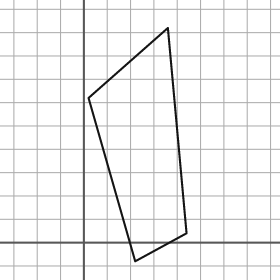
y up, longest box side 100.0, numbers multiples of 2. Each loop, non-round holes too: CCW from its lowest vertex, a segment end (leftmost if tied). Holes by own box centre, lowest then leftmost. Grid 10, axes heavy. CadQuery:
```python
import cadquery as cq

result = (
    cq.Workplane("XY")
    .moveTo(22.0, -8.0)
    .lineTo(44.0, 4.0)
    .lineTo(36.0, 92.0)
    .lineTo(2.0, 62.0)
    .close()
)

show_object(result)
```